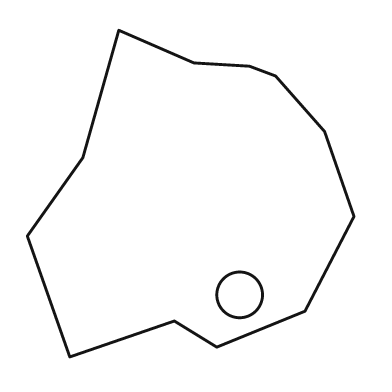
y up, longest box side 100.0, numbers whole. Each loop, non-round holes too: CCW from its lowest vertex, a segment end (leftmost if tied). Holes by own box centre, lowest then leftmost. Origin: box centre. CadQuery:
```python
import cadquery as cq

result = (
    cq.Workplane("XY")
    .moveTo(-37.0, -50.0)
    .lineTo(-5.0, -39.0)
    .lineTo(8.0, -47.0)
    .lineTo(35.0, -36.0)
    .lineTo(50.0, -7.0)
    .lineTo(41.0, 19.0)
    .lineTo(26.0, 36.0)
    .lineTo(18.0, 39.0)
    .lineTo(1.0, 40.0)
    .lineTo(-22.0, 50.0)
    .lineTo(-33.0, 11.0)
    .lineTo(-50.0, -13.0)
    .close()
    .moveTo(15.0, -31.0)
    .circle(7.0)
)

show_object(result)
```